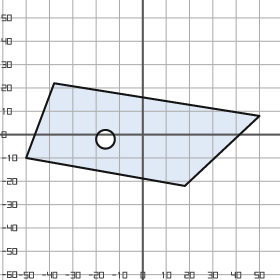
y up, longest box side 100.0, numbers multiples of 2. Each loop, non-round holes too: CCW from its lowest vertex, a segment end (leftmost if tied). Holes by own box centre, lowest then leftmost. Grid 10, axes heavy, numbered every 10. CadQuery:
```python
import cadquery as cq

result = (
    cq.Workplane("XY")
    .moveTo(18.0, -22.0)
    .lineTo(50.0, 8.0)
    .lineTo(-38.0, 22.0)
    .lineTo(-50.0, -10.0)
    .close()
    .moveTo(-16.0, -2.0)
    .circle(4.0)
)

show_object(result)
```